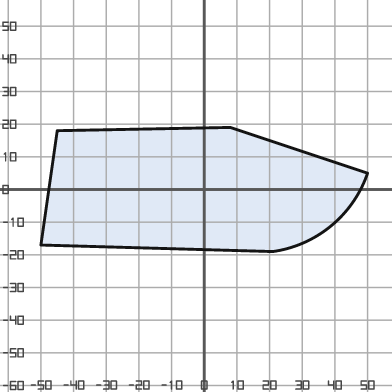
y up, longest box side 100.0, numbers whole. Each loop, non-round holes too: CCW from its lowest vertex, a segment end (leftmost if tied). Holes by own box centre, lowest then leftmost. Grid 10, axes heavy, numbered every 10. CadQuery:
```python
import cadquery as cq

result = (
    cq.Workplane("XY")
    .moveTo(21.0, -19.0)
    .threePointArc((39.0, -11.0), (50.0, 5.0))
    .lineTo(8.0, 19.0)
    .lineTo(-45.0, 18.0)
    .lineTo(-50.0, -17.0)
    .close()
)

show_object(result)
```